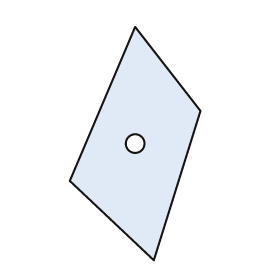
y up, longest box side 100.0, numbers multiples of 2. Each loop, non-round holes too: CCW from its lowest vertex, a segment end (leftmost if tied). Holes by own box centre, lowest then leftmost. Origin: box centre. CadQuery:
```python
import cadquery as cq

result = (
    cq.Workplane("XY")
    .moveTo(8.0, -50.0)
    .lineTo(28.0, 14.0)
    .lineTo(0.0, 50.0)
    .lineTo(-28.0, -16.0)
    .close()
    .moveTo(0.0, 0.0)
    .circle(4.0)
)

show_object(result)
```